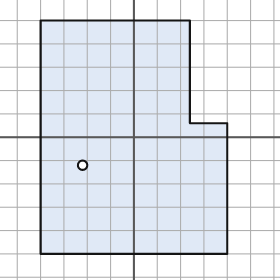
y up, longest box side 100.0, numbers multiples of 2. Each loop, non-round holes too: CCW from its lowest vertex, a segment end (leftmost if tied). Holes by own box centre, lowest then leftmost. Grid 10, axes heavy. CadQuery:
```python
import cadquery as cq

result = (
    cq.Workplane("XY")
    .moveTo(-40.0, -50.0)
    .lineTo(40.0, -50.0)
    .lineTo(40.0, 6.0)
    .lineTo(24.0, 6.0)
    .lineTo(24.0, 50.0)
    .lineTo(-40.0, 50.0)
    .close()
    .moveTo(-22.0, -12.0)
    .circle(2.0)
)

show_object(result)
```